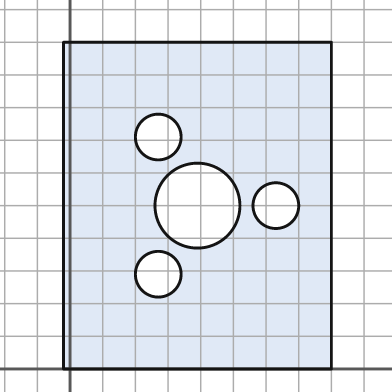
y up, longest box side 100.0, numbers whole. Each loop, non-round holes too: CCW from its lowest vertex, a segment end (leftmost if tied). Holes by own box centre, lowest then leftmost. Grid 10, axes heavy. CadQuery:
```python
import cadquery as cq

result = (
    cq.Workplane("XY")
    .moveTo(-2.0, 0.0)
    .lineTo(80.0, 0.0)
    .lineTo(80.0, 100.0)
    .lineTo(-2.0, 100.0)
    .close()
    .moveTo(27.0, 29.0)
    .circle(7.0)
    .moveTo(39.0, 50.0)
    .circle(13.0)
    .moveTo(63.0, 50.0)
    .circle(7.0)
    .moveTo(27.0, 71.0)
    .circle(7.0)
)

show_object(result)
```